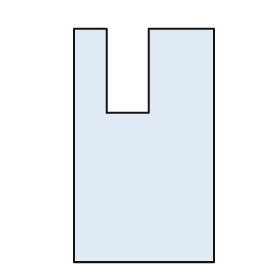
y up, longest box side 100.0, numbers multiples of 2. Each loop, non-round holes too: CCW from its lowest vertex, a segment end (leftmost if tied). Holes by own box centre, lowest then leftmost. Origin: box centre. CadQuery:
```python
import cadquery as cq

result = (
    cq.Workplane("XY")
    .moveTo(-30.0, -50.0)
    .lineTo(30.0, -50.0)
    .lineTo(30.0, 50.0)
    .lineTo(2.0, 50.0)
    .lineTo(2.0, 14.0)
    .lineTo(-16.0, 14.0)
    .lineTo(-16.0, 50.0)
    .lineTo(-30.0, 50.0)
    .close()
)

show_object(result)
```